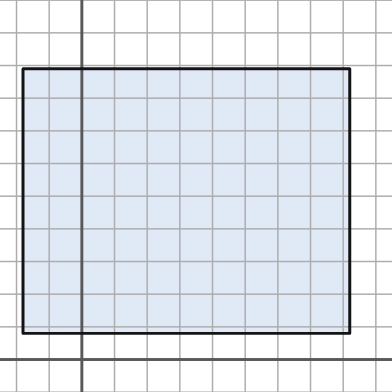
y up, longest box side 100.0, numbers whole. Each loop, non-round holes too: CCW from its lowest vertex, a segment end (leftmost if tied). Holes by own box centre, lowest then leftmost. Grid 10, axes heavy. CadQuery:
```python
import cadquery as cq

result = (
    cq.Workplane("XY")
    .moveTo(-18.0, 8.0)
    .lineTo(82.0, 8.0)
    .lineTo(82.0, 89.0)
    .lineTo(-18.0, 89.0)
    .close()
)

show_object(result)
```